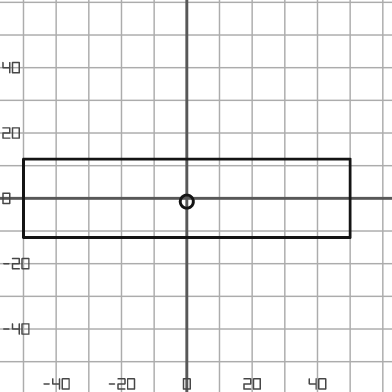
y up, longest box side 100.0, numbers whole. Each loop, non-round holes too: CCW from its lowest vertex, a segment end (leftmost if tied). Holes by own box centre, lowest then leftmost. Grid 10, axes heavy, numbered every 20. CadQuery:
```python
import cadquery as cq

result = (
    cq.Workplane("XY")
    .moveTo(-50.0, -12.0)
    .lineTo(50.0, -12.0)
    .lineTo(50.0, 12.0)
    .lineTo(-50.0, 12.0)
    .close()
    .moveTo(0.0, -1.0)
    .circle(2.0)
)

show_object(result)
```